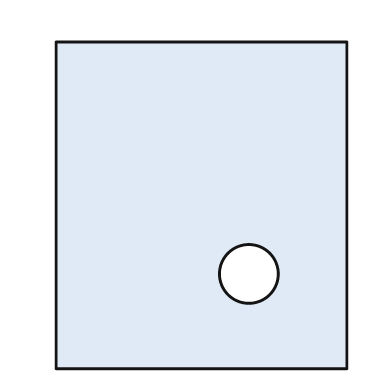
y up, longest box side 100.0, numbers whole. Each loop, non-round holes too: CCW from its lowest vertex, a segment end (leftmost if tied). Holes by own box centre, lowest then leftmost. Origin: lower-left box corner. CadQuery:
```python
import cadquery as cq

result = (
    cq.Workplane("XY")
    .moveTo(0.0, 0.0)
    .lineTo(89.0, 0.0)
    .lineTo(89.0, 100.0)
    .lineTo(0.0, 100.0)
    .close()
    .moveTo(59.0, 29.0)
    .circle(9.0)
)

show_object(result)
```